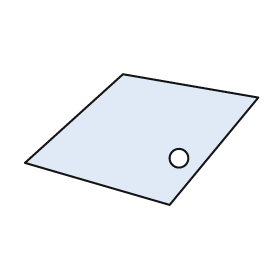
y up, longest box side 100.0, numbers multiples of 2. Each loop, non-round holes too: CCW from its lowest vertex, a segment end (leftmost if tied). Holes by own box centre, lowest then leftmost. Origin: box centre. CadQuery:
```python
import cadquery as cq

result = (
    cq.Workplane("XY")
    .moveTo(12.0, -28.0)
    .lineTo(50.0, 18.0)
    .lineTo(-8.0, 28.0)
    .lineTo(-50.0, -10.0)
    .close()
    .moveTo(16.0, -8.0)
    .circle(4.0)
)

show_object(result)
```